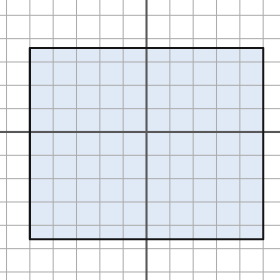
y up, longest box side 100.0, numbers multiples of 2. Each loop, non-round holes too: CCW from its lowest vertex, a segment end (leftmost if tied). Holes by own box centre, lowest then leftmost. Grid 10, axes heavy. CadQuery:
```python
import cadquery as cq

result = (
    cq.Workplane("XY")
    .moveTo(-50.0, -46.0)
    .lineTo(50.0, -46.0)
    .lineTo(50.0, 36.0)
    .lineTo(-50.0, 36.0)
    .close()
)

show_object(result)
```